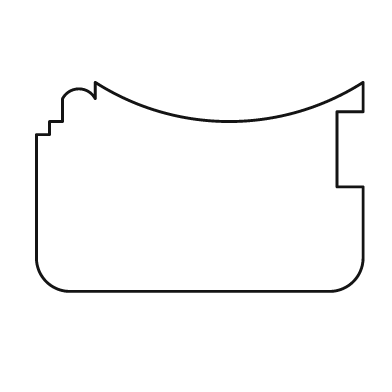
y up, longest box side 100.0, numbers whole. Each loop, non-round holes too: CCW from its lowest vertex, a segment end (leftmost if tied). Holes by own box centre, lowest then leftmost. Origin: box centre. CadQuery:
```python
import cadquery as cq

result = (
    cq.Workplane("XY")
    .moveTo(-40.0, -32.0)
    .lineTo(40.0, -32.0)
    .threePointArc((47.0, -29.0), (50.0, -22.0))
    .lineTo(50.0, 0.0)
    .lineTo(42.0, 0.0)
    .lineTo(42.0, 23.0)
    .lineTo(50.0, 23.0)
    .lineTo(50.0, 32.0)
    .threePointArc((9.0, 20.0), (-32.0, 32.0))
    .lineTo(-32.0, 27.0)
    .threePointArc((-37.0, 30.0), (-42.0, 27.0))
    .lineTo(-42.0, 20.0)
    .lineTo(-46.0, 20.0)
    .lineTo(-46.0, 16.0)
    .lineTo(-50.0, 16.0)
    .lineTo(-50.0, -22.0)
    .threePointArc((-47.0, -29.0), (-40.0, -32.0))
    .close()
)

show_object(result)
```